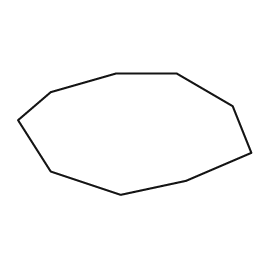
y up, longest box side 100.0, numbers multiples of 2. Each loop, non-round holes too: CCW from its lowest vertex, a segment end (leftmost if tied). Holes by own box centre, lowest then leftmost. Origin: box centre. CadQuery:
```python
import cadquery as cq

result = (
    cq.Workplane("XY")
    .moveTo(-6.0, -26.0)
    .lineTo(22.0, -20.0)
    .lineTo(50.0, -8.0)
    .lineTo(42.0, 12.0)
    .lineTo(18.0, 26.0)
    .lineTo(-8.0, 26.0)
    .lineTo(-36.0, 18.0)
    .lineTo(-50.0, 6.0)
    .lineTo(-36.0, -16.0)
    .close()
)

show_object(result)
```